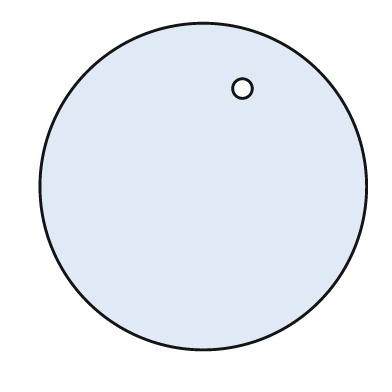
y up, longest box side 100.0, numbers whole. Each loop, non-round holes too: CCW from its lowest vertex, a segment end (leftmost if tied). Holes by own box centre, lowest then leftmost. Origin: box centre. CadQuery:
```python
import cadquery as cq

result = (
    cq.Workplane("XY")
    .moveTo(0.0, 0.0)
    .circle(50.0)
    .moveTo(12.0, 30.0)
    .circle(3.0)
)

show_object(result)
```